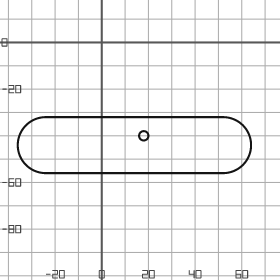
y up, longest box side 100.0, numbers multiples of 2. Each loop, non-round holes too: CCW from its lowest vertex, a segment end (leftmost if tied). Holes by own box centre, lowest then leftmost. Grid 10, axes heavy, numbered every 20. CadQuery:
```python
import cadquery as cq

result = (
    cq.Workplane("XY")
    .moveTo(-24.0, -56.0)
    .lineTo(52.0, -56.0)
    .threePointArc((64.0, -44.0), (52.0, -32.0))
    .lineTo(-24.0, -32.0)
    .threePointArc((-36.0, -44.0), (-24.0, -56.0))
    .close()
    .moveTo(18.0, -40.0)
    .circle(2.0)
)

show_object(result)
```